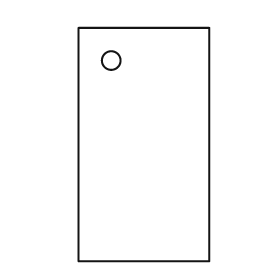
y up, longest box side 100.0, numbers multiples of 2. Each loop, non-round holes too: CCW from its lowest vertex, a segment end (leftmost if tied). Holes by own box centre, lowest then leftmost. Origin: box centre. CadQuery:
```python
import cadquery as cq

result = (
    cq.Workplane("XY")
    .moveTo(-28.0, -50.0)
    .lineTo(28.0, -50.0)
    .lineTo(28.0, 50.0)
    .lineTo(-28.0, 50.0)
    .close()
    .moveTo(-14.0, 36.0)
    .circle(4.0)
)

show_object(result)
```